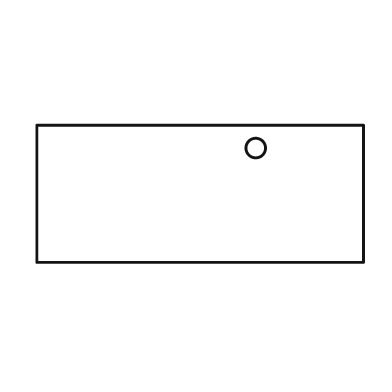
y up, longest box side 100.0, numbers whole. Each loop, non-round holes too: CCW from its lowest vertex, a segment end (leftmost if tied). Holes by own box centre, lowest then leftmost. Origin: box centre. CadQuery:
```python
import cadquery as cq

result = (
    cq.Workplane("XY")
    .moveTo(-50.0, -21.0)
    .lineTo(50.0, -21.0)
    .lineTo(50.0, 21.0)
    .lineTo(-50.0, 21.0)
    .close()
    .moveTo(17.0, 14.0)
    .circle(3.0)
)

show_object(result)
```